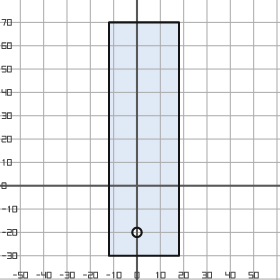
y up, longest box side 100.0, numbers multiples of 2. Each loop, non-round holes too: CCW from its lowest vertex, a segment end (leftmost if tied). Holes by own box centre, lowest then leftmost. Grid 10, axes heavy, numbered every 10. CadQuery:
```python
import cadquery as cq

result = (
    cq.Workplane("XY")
    .moveTo(-12.0, -30.0)
    .lineTo(18.0, -30.0)
    .lineTo(18.0, 70.0)
    .lineTo(-12.0, 70.0)
    .close()
    .moveTo(0.0, -20.0)
    .circle(2.0)
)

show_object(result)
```